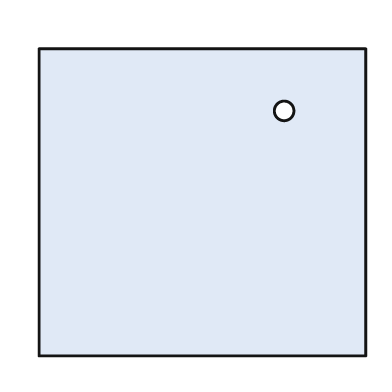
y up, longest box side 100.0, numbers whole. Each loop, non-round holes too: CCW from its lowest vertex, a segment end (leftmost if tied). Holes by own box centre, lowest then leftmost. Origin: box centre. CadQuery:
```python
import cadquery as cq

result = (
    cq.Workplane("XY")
    .moveTo(-50.0, -47.0)
    .lineTo(50.0, -47.0)
    .lineTo(50.0, 47.0)
    .lineTo(-50.0, 47.0)
    .close()
    .moveTo(25.0, 28.0)
    .circle(3.0)
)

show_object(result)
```